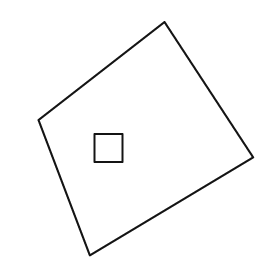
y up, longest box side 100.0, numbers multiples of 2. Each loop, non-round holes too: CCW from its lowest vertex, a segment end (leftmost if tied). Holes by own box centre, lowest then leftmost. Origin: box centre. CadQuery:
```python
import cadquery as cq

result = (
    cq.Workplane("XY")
    .moveTo(-24.0, -50.0)
    .lineTo(46.0, -8.0)
    .lineTo(8.0, 50.0)
    .lineTo(-46.0, 8.0)
    .close()
    .moveTo(-22.0, -10.0)
    .lineTo(-10.0, -10.0)
    .lineTo(-10.0, 2.0)
    .lineTo(-22.0, 2.0)
    .close()
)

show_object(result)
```